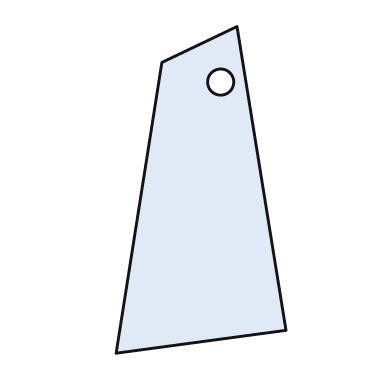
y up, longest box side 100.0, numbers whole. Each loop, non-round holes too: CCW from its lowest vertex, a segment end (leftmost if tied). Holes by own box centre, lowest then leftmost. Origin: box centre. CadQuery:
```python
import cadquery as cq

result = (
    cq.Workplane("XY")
    .moveTo(-26.0, -50.0)
    .lineTo(26.0, -43.0)
    .lineTo(11.0, 50.0)
    .lineTo(-12.0, 39.0)
    .close()
    .moveTo(6.0, 33.0)
    .circle(4.0)
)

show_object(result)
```